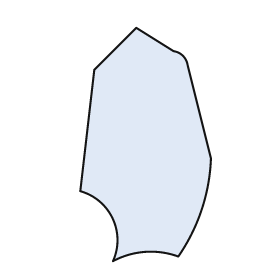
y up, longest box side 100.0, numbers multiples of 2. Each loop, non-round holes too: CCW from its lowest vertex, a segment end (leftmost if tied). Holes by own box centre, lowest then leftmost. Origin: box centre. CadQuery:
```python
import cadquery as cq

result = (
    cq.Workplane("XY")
    .moveTo(-14.0, -50.0)
    .threePointArc((0.0, -46.0), (14.0, -48.0))
    .threePointArc((24.0, -28.0), (28.0, -6.0))
    .lineTo(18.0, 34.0)
    .threePointArc((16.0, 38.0), (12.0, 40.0))
    .lineTo(-4.0, 50.0)
    .lineTo(-22.0, 32.0)
    .lineTo(-28.0, -20.0)
    .threePointArc((-14.0, -32.0), (-14.0, -50.0))
    .close()
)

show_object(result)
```